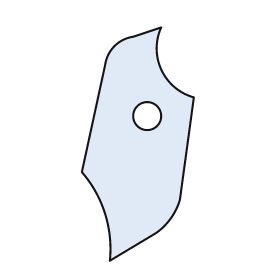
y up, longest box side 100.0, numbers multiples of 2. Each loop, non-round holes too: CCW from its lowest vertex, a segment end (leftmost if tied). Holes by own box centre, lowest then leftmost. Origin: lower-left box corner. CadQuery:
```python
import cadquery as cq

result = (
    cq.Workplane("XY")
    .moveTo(12.0, 0.0)
    .lineTo(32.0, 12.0)
    .threePointArc((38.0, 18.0), (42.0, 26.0))
    .lineTo(48.0, 70.0)
    .threePointArc((34.0, 82.0), (34.0, 100.0))
    .lineTo(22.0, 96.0)
    .threePointArc((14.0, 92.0), (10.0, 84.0))
    .lineTo(0.0, 38.0)
    .threePointArc((10.0, 20.0), (12.0, 0.0))
    .close()
    .moveTo(28.0, 62.0)
    .circle(6.0)
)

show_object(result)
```